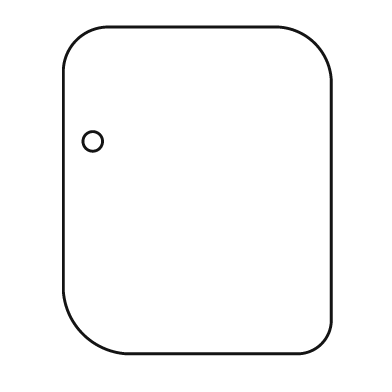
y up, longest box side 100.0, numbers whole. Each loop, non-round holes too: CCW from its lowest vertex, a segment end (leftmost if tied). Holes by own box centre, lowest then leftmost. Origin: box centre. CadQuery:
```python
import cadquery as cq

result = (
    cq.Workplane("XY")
    .moveTo(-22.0, -50.0)
    .lineTo(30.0, -50.0)
    .threePointArc((38.0, -47.0), (41.0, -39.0))
    .lineTo(41.0, 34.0)
    .threePointArc((36.0, 45.0), (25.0, 50.0))
    .lineTo(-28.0, 50.0)
    .threePointArc((-37.0, 46.0), (-41.0, 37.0))
    .lineTo(-41.0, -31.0)
    .threePointArc((-35.0, -44.0), (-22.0, -50.0))
    .close()
    .moveTo(-32.0, 15.0)
    .circle(3.0)
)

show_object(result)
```